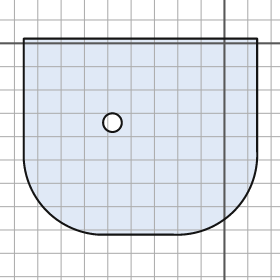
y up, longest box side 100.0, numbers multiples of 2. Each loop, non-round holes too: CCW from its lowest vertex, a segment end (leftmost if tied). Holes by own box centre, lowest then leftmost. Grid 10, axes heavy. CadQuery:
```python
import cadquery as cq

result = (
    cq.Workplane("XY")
    .moveTo(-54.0, -82.0)
    .lineTo(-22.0, -82.0)
    .threePointArc((4.0, -72.0), (14.0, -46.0))
    .lineTo(14.0, 2.0)
    .lineTo(-86.0, 2.0)
    .lineTo(-86.0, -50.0)
    .threePointArc((-76.0, -72.0), (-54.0, -82.0))
    .close()
    .moveTo(-48.0, -34.0)
    .circle(4.0)
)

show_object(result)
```